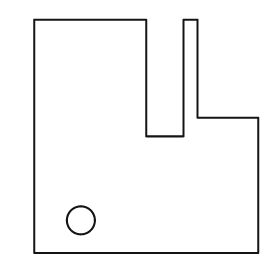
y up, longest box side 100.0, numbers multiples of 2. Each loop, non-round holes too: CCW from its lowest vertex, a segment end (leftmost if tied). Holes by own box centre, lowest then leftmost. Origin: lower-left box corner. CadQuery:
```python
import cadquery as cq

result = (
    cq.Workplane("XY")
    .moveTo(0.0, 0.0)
    .lineTo(96.0, 0.0)
    .lineTo(96.0, 58.0)
    .lineTo(70.0, 58.0)
    .lineTo(70.0, 100.0)
    .lineTo(64.0, 100.0)
    .lineTo(64.0, 50.0)
    .lineTo(48.0, 50.0)
    .lineTo(48.0, 100.0)
    .lineTo(0.0, 100.0)
    .close()
    .moveTo(20.0, 14.0)
    .circle(6.0)
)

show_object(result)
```